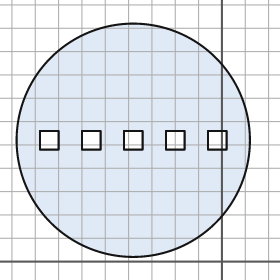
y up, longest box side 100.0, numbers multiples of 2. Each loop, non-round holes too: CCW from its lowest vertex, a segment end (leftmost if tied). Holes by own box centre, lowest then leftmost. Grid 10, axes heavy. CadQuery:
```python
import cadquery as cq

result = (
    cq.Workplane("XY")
    .moveTo(-38.0, 52.0)
    .circle(50.0)
    .moveTo(-78.0, 48.0)
    .lineTo(-70.0, 48.0)
    .lineTo(-70.0, 56.0)
    .lineTo(-78.0, 56.0)
    .close()
    .moveTo(-60.0, 48.0)
    .lineTo(-52.0, 48.0)
    .lineTo(-52.0, 56.0)
    .lineTo(-60.0, 56.0)
    .close()
    .moveTo(-42.0, 48.0)
    .lineTo(-34.0, 48.0)
    .lineTo(-34.0, 56.0)
    .lineTo(-42.0, 56.0)
    .close()
    .moveTo(-24.0, 48.0)
    .lineTo(-16.0, 48.0)
    .lineTo(-16.0, 56.0)
    .lineTo(-24.0, 56.0)
    .close()
    .moveTo(-6.0, 48.0)
    .lineTo(2.0, 48.0)
    .lineTo(2.0, 56.0)
    .lineTo(-6.0, 56.0)
    .close()
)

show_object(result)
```